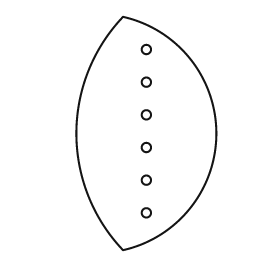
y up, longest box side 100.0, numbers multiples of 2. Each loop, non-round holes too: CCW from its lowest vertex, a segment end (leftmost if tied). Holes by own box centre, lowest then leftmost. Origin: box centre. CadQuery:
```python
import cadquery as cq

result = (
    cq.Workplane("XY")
    .moveTo(-10.0, -50.0)
    .threePointArc((30.0, 0.0), (-10.0, 50.0))
    .threePointArc((-30.0, 0.0), (-10.0, -50.0))
    .close()
    .moveTo(0.0, -34.0)
    .circle(2.0)
    .moveTo(0.0, -20.0)
    .circle(2.0)
    .moveTo(0.0, -6.0)
    .circle(2.0)
    .moveTo(0.0, 8.0)
    .circle(2.0)
    .moveTo(0.0, 22.0)
    .circle(2.0)
    .moveTo(0.0, 36.0)
    .circle(2.0)
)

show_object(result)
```